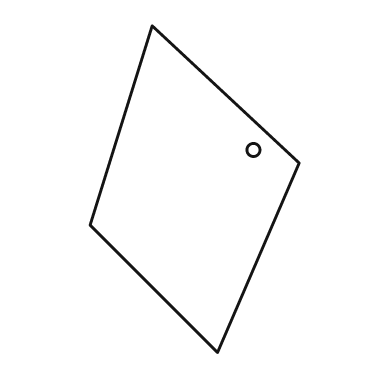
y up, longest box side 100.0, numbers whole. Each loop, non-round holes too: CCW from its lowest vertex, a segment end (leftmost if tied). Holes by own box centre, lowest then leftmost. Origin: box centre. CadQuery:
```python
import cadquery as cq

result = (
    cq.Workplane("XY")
    .moveTo(7.0, -50.0)
    .lineTo(32.0, 8.0)
    .lineTo(-13.0, 50.0)
    .lineTo(-32.0, -11.0)
    .close()
    .moveTo(18.0, 12.0)
    .circle(2.0)
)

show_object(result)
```